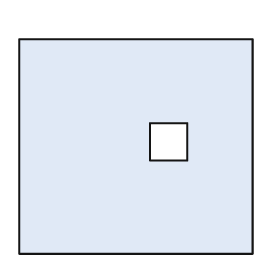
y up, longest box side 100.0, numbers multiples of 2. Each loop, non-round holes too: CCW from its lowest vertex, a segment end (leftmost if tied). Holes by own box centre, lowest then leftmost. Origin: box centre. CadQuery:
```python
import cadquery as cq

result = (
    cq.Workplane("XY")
    .moveTo(-50.0, -46.0)
    .lineTo(50.0, -46.0)
    .lineTo(50.0, 46.0)
    .lineTo(-50.0, 46.0)
    .close()
    .moveTo(6.0, -6.0)
    .lineTo(22.0, -6.0)
    .lineTo(22.0, 10.0)
    .lineTo(6.0, 10.0)
    .close()
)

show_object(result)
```